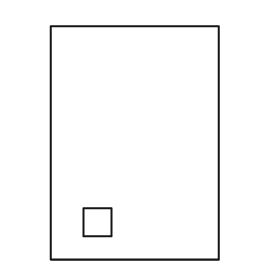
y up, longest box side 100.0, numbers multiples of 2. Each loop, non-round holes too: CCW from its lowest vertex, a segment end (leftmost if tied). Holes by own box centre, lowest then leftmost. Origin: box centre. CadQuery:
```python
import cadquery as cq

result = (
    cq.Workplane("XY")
    .moveTo(-36.0, -50.0)
    .lineTo(36.0, -50.0)
    .lineTo(36.0, 50.0)
    .lineTo(-36.0, 50.0)
    .close()
    .moveTo(-22.0, -40.0)
    .lineTo(-10.0, -40.0)
    .lineTo(-10.0, -28.0)
    .lineTo(-22.0, -28.0)
    .close()
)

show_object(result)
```